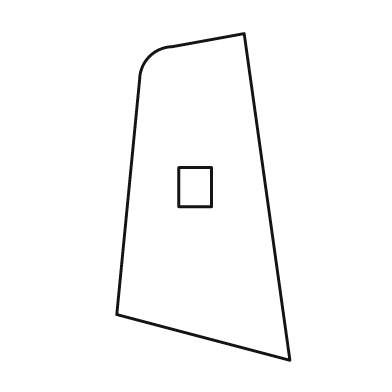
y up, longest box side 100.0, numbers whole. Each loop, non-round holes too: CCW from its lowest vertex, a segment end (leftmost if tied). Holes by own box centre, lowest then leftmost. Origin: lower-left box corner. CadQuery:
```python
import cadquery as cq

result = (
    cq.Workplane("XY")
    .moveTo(53.0, 0.0)
    .lineTo(39.0, 100.0)
    .lineTo(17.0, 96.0)
    .threePointArc((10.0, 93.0), (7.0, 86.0))
    .lineTo(0.0, 14.0)
    .close()
    .moveTo(19.0, 47.0)
    .lineTo(29.0, 47.0)
    .lineTo(29.0, 59.0)
    .lineTo(19.0, 59.0)
    .close()
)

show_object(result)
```